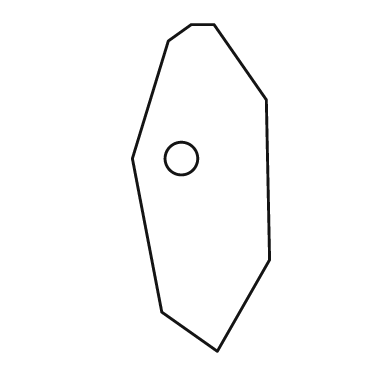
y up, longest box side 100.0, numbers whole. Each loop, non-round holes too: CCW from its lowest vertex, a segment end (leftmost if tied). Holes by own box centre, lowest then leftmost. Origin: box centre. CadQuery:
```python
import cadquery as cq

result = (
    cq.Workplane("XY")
    .moveTo(5.0, -50.0)
    .lineTo(21.0, -22.0)
    .lineTo(20.0, 27.0)
    .lineTo(4.0, 50.0)
    .lineTo(-3.0, 50.0)
    .lineTo(-10.0, 45.0)
    .lineTo(-21.0, 9.0)
    .lineTo(-12.0, -38.0)
    .close()
    .moveTo(-6.0, 9.0)
    .circle(5.0)
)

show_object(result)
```